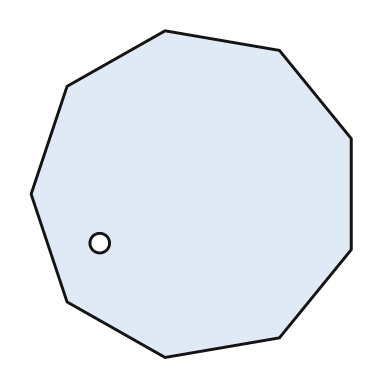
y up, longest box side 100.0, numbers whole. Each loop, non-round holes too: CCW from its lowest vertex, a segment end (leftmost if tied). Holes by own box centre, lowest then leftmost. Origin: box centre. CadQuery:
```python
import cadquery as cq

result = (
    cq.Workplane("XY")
    .moveTo(-8.0, -50.0)
    .lineTo(27.0, -44.0)
    .lineTo(49.0, -17.0)
    .lineTo(49.0, 17.0)
    .lineTo(27.0, 44.0)
    .lineTo(-8.0, 50.0)
    .lineTo(-38.0, 33.0)
    .lineTo(-49.0, 0.0)
    .lineTo(-38.0, -33.0)
    .close()
    .moveTo(-28.0, -15.0)
    .circle(3.0)
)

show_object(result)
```